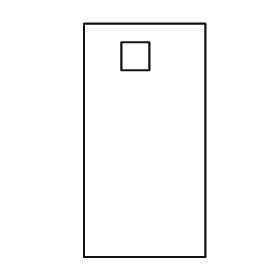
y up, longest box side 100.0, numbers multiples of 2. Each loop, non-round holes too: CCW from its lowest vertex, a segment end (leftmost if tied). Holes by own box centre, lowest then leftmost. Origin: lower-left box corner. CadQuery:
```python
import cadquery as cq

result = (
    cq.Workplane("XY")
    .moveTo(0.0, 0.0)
    .lineTo(52.0, 0.0)
    .lineTo(52.0, 100.0)
    .lineTo(0.0, 100.0)
    .close()
    .moveTo(16.0, 80.0)
    .lineTo(28.0, 80.0)
    .lineTo(28.0, 92.0)
    .lineTo(16.0, 92.0)
    .close()
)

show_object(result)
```